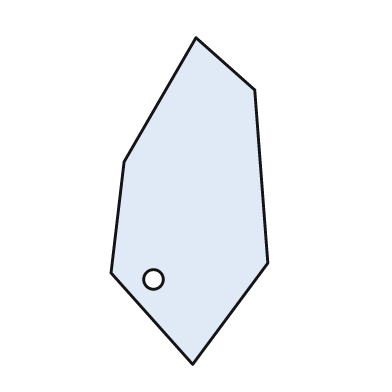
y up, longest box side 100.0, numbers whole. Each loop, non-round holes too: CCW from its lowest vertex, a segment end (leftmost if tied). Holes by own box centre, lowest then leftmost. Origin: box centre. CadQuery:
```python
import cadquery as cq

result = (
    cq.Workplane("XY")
    .moveTo(1.0, -50.0)
    .lineTo(24.0, -19.0)
    .lineTo(20.0, 34.0)
    .lineTo(2.0, 50.0)
    .lineTo(-20.0, 12.0)
    .lineTo(-24.0, -22.0)
    .close()
    .moveTo(-11.0, -24.0)
    .circle(3.0)
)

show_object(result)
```